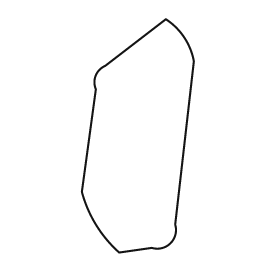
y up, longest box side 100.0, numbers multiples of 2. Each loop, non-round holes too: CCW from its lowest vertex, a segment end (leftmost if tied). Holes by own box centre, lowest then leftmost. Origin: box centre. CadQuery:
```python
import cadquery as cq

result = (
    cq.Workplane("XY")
    .moveTo(-8.0, -50.0)
    .lineTo(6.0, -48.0)
    .threePointArc((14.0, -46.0), (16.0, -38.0))
    .lineTo(24.0, 32.0)
    .threePointArc((20.0, 42.0), (12.0, 50.0))
    .lineTo(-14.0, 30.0)
    .threePointArc((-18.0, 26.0), (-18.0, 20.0))
    .lineTo(-24.0, -24.0)
    .threePointArc((-18.0, -38.0), (-8.0, -50.0))
    .close()
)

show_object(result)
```